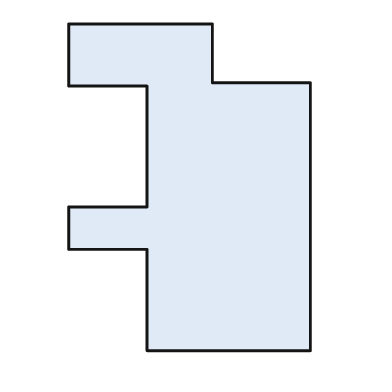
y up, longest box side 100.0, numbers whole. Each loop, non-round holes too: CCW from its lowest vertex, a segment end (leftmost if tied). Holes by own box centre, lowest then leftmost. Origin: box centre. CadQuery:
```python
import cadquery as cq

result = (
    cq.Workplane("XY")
    .moveTo(-13.0, -50.0)
    .lineTo(37.0, -50.0)
    .lineTo(37.0, 32.0)
    .lineTo(7.0, 32.0)
    .lineTo(7.0, 50.0)
    .lineTo(-37.0, 50.0)
    .lineTo(-37.0, 31.0)
    .lineTo(-13.0, 31.0)
    .lineTo(-13.0, -6.0)
    .lineTo(-37.0, -6.0)
    .lineTo(-37.0, -19.0)
    .lineTo(-13.0, -19.0)
    .close()
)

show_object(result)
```